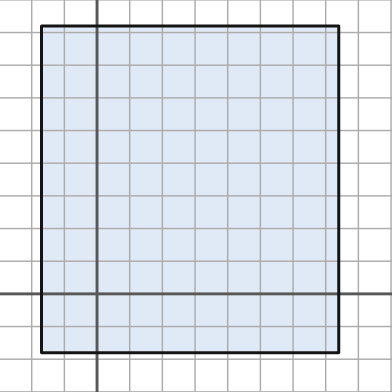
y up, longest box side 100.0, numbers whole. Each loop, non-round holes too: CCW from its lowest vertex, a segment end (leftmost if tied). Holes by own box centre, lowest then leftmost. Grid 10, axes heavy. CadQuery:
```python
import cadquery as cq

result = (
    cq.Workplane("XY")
    .moveTo(-17.0, -18.0)
    .lineTo(74.0, -18.0)
    .lineTo(74.0, 82.0)
    .lineTo(-17.0, 82.0)
    .close()
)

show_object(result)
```